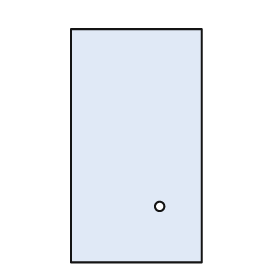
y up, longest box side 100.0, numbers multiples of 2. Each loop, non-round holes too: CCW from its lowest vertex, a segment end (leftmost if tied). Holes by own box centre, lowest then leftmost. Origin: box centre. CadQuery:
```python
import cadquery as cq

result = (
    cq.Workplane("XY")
    .moveTo(-28.0, -50.0)
    .lineTo(28.0, -50.0)
    .lineTo(28.0, 50.0)
    .lineTo(-28.0, 50.0)
    .close()
    .moveTo(10.0, -26.0)
    .circle(2.0)
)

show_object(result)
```